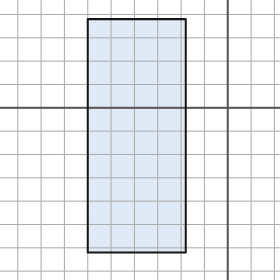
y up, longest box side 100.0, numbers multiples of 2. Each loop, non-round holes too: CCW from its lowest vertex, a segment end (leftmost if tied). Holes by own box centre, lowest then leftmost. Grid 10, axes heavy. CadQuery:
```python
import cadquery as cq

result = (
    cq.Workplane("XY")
    .moveTo(-60.0, -62.0)
    .lineTo(-18.0, -62.0)
    .lineTo(-18.0, 38.0)
    .lineTo(-60.0, 38.0)
    .close()
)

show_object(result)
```